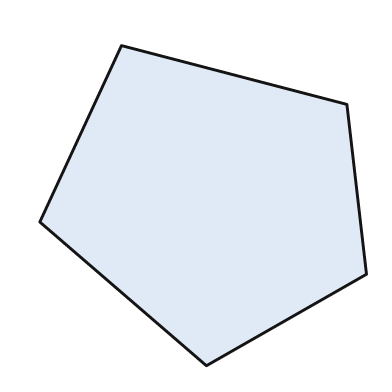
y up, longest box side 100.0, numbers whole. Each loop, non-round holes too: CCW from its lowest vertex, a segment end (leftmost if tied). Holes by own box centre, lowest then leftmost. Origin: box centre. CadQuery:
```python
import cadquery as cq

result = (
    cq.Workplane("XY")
    .moveTo(1.0, -49.0)
    .lineTo(50.0, -21.0)
    .lineTo(44.0, 31.0)
    .lineTo(-25.0, 49.0)
    .lineTo(-50.0, -5.0)
    .close()
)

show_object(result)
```